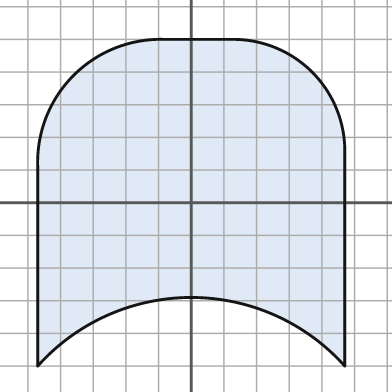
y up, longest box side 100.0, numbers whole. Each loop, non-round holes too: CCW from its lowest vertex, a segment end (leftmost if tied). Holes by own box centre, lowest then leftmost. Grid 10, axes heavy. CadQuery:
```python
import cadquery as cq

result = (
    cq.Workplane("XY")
    .moveTo(-47.0, -50.0)
    .threePointArc((0.0, -29.0), (47.0, -50.0))
    .lineTo(47.0, 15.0)
    .threePointArc((37.0, 40.0), (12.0, 50.0))
    .lineTo(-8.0, 50.0)
    .threePointArc((-36.0, 39.0), (-47.0, 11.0))
    .close()
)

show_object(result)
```